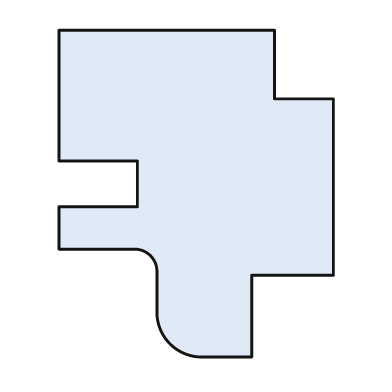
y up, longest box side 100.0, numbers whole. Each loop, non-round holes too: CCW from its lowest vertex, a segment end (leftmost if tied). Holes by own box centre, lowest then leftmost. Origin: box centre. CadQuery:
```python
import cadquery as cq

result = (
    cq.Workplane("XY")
    .moveTo(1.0, -50.0)
    .lineTo(17.0, -50.0)
    .lineTo(17.0, -25.0)
    .lineTo(42.0, -25.0)
    .lineTo(42.0, 29.0)
    .lineTo(24.0, 29.0)
    .lineTo(24.0, 50.0)
    .lineTo(-42.0, 50.0)
    .lineTo(-42.0, 10.0)
    .lineTo(-18.0, 10.0)
    .lineTo(-18.0, -4.0)
    .lineTo(-42.0, -4.0)
    .lineTo(-42.0, -17.0)
    .lineTo(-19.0, -17.0)
    .threePointArc((-14.0, -19.0), (-12.0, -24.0))
    .lineTo(-12.0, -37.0)
    .threePointArc((-8.0, -46.0), (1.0, -50.0))
    .close()
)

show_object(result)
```